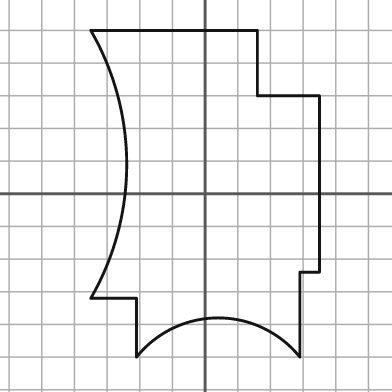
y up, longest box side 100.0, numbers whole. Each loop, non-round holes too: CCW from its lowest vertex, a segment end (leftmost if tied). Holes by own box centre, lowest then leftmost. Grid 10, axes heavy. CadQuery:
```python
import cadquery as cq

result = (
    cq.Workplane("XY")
    .moveTo(-21.0, -50.0)
    .threePointArc((4.0, -38.0), (29.0, -50.0))
    .lineTo(29.0, -24.0)
    .lineTo(35.0, -24.0)
    .lineTo(35.0, 30.0)
    .lineTo(16.0, 30.0)
    .lineTo(16.0, 50.0)
    .lineTo(-35.0, 50.0)
    .threePointArc((-24.0, 9.0), (-35.0, -32.0))
    .lineTo(-21.0, -32.0)
    .close()
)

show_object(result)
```